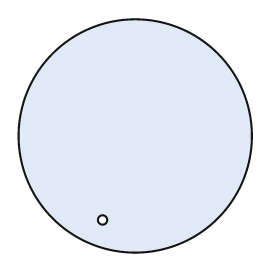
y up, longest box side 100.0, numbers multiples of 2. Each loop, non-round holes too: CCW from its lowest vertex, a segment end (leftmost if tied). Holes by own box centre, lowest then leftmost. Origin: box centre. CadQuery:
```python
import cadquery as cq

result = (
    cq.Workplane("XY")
    .moveTo(0.0, 0.0)
    .circle(50.0)
    .moveTo(-14.0, -36.0)
    .circle(2.0)
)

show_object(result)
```